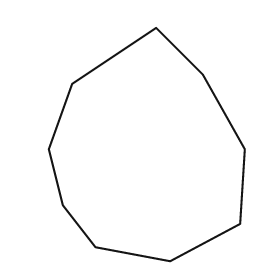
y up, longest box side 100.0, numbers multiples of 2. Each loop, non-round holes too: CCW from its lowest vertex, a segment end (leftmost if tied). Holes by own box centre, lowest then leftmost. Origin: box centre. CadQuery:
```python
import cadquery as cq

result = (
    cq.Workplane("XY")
    .moveTo(10.0, -50.0)
    .lineTo(40.0, -34.0)
    .lineTo(42.0, -2.0)
    .lineTo(24.0, 30.0)
    .lineTo(4.0, 50.0)
    .lineTo(-32.0, 26.0)
    .lineTo(-42.0, -2.0)
    .lineTo(-36.0, -26.0)
    .lineTo(-22.0, -44.0)
    .close()
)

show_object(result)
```